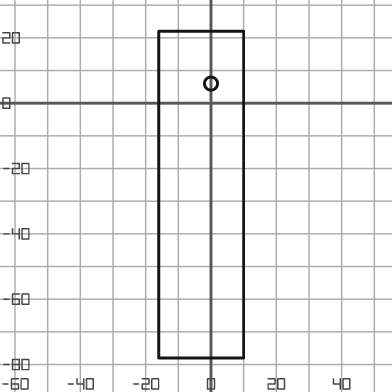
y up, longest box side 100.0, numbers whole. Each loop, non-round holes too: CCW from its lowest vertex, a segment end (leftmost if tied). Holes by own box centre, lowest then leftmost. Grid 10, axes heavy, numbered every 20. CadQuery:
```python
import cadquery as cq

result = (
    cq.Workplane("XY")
    .moveTo(-16.0, -78.0)
    .lineTo(10.0, -78.0)
    .lineTo(10.0, 22.0)
    .lineTo(-16.0, 22.0)
    .close()
    .moveTo(0.0, 6.0)
    .circle(2.0)
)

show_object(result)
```